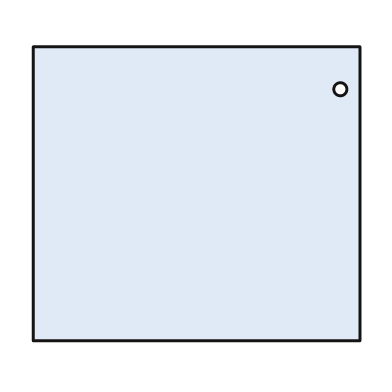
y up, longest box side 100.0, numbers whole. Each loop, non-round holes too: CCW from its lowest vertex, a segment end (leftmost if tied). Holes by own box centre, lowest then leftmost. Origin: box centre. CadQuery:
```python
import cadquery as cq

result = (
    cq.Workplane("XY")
    .moveTo(-50.0, -45.0)
    .lineTo(50.0, -45.0)
    .lineTo(50.0, 45.0)
    .lineTo(-50.0, 45.0)
    .close()
    .moveTo(44.0, 32.0)
    .circle(2.0)
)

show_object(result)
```